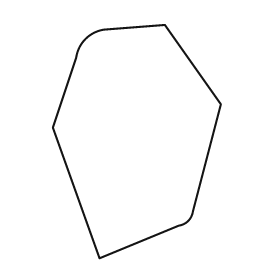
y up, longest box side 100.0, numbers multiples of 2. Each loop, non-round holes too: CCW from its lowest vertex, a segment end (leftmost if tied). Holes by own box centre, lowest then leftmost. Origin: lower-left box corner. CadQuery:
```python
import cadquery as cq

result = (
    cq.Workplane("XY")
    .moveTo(20.0, 0.0)
    .lineTo(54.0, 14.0)
    .threePointArc((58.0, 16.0), (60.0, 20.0))
    .lineTo(72.0, 66.0)
    .lineTo(48.0, 100.0)
    .lineTo(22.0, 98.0)
    .threePointArc((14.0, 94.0), (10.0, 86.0))
    .lineTo(0.0, 56.0)
    .close()
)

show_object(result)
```